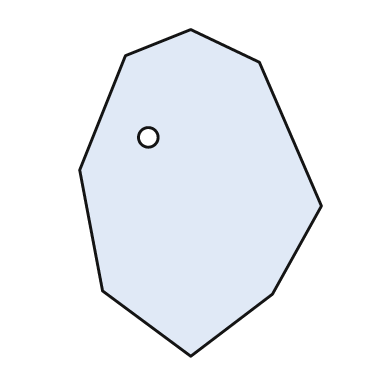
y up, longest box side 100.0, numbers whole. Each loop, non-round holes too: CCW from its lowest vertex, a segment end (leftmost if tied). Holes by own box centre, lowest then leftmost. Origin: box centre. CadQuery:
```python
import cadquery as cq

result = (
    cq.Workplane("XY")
    .moveTo(-3.0, -50.0)
    .lineTo(22.0, -31.0)
    .lineTo(37.0, -4.0)
    .lineTo(18.0, 40.0)
    .lineTo(-3.0, 50.0)
    .lineTo(-23.0, 42.0)
    .lineTo(-37.0, 7.0)
    .lineTo(-30.0, -30.0)
    .close()
    .moveTo(-16.0, 17.0)
    .circle(3.0)
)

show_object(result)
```